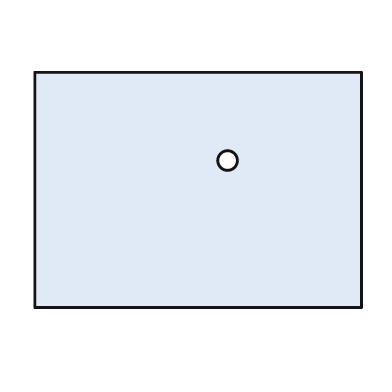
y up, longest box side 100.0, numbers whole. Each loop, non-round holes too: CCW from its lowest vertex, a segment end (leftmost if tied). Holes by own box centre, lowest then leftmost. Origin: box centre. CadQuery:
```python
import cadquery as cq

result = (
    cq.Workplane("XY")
    .moveTo(-50.0, -36.0)
    .lineTo(50.0, -36.0)
    .lineTo(50.0, 36.0)
    .lineTo(-50.0, 36.0)
    .close()
    .moveTo(9.0, 9.0)
    .circle(3.0)
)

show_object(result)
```